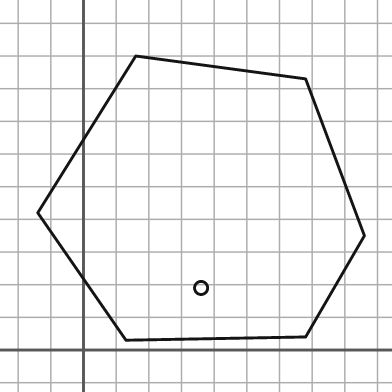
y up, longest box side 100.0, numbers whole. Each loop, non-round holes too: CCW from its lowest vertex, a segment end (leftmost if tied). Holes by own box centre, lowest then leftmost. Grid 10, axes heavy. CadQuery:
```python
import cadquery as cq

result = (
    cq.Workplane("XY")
    .moveTo(13.0, 3.0)
    .lineTo(68.0, 4.0)
    .lineTo(86.0, 35.0)
    .lineTo(68.0, 83.0)
    .lineTo(16.0, 90.0)
    .lineTo(-14.0, 42.0)
    .close()
    .moveTo(36.0, 19.0)
    .circle(2.0)
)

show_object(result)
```